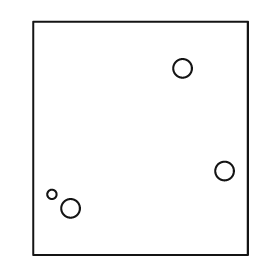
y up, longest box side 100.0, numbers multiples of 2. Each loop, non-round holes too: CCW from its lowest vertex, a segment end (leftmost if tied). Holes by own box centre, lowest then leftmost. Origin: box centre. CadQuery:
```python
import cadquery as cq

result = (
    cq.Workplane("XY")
    .moveTo(-46.0, -50.0)
    .lineTo(46.0, -50.0)
    .lineTo(46.0, 50.0)
    .lineTo(-46.0, 50.0)
    .close()
    .moveTo(-30.0, -30.0)
    .circle(4.0)
    .moveTo(-38.0, -24.0)
    .circle(2.0)
    .moveTo(36.0, -14.0)
    .circle(4.0)
    .moveTo(18.0, 30.0)
    .circle(4.0)
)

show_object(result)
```